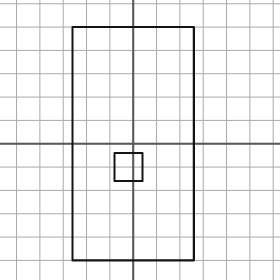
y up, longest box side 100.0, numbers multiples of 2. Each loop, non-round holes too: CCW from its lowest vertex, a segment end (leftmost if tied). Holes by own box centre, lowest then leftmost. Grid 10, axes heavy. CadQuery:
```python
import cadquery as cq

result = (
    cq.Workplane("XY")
    .moveTo(-26.0, -50.0)
    .lineTo(26.0, -50.0)
    .lineTo(26.0, 50.0)
    .lineTo(-26.0, 50.0)
    .close()
    .moveTo(-8.0, -16.0)
    .lineTo(4.0, -16.0)
    .lineTo(4.0, -4.0)
    .lineTo(-8.0, -4.0)
    .close()
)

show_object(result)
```